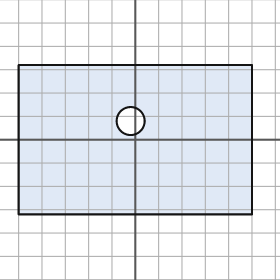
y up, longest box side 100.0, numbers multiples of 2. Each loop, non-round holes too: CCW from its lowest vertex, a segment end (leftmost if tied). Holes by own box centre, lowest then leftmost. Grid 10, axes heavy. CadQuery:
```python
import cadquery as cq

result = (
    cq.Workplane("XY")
    .moveTo(-50.0, -32.0)
    .lineTo(50.0, -32.0)
    .lineTo(50.0, 32.0)
    .lineTo(-50.0, 32.0)
    .close()
    .moveTo(-2.0, 8.0)
    .circle(6.0)
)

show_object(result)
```